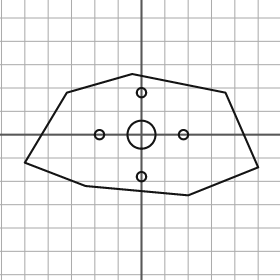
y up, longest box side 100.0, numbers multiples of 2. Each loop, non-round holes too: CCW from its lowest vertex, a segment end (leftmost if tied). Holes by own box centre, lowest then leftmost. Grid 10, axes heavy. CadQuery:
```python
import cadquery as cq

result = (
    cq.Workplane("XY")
    .moveTo(20.0, -26.0)
    .lineTo(50.0, -14.0)
    .lineTo(36.0, 18.0)
    .lineTo(-4.0, 26.0)
    .lineTo(-32.0, 18.0)
    .lineTo(-50.0, -12.0)
    .lineTo(-24.0, -22.0)
    .close()
    .moveTo(0.0, -18.0)
    .circle(2.0)
    .moveTo(-18.0, 0.0)
    .circle(2.0)
    .moveTo(0.0, 0.0)
    .circle(6.0)
    .moveTo(18.0, 0.0)
    .circle(2.0)
    .moveTo(0.0, 18.0)
    .circle(2.0)
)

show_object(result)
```